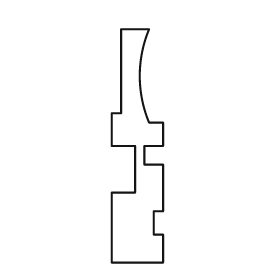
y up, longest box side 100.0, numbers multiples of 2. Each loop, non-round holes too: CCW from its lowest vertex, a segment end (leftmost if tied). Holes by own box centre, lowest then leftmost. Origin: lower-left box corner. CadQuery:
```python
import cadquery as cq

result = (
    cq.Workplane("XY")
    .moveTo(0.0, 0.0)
    .lineTo(22.0, 0.0)
    .lineTo(22.0, 12.0)
    .lineTo(18.0, 12.0)
    .lineTo(18.0, 22.0)
    .lineTo(22.0, 22.0)
    .lineTo(22.0, 42.0)
    .lineTo(14.0, 42.0)
    .lineTo(14.0, 50.0)
    .lineTo(22.0, 50.0)
    .lineTo(22.0, 60.0)
    .lineTo(16.0, 60.0)
    .threePointArc((12.0, 80.0), (16.0, 100.0))
    .lineTo(4.0, 100.0)
    .lineTo(4.0, 64.0)
    .lineTo(0.0, 64.0)
    .lineTo(0.0, 50.0)
    .lineTo(10.0, 50.0)
    .lineTo(10.0, 30.0)
    .lineTo(0.0, 30.0)
    .close()
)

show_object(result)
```